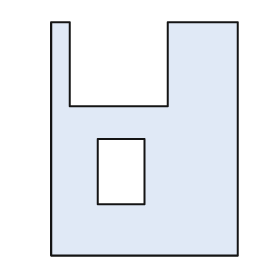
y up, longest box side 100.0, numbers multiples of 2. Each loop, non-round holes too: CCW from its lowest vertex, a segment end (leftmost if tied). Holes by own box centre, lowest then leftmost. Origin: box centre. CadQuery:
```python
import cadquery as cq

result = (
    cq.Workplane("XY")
    .moveTo(-40.0, -50.0)
    .lineTo(40.0, -50.0)
    .lineTo(40.0, 50.0)
    .lineTo(10.0, 50.0)
    .lineTo(10.0, 14.0)
    .lineTo(-32.0, 14.0)
    .lineTo(-32.0, 50.0)
    .lineTo(-40.0, 50.0)
    .close()
    .moveTo(-20.0, -28.0)
    .lineTo(0.0, -28.0)
    .lineTo(0.0, 0.0)
    .lineTo(-20.0, 0.0)
    .close()
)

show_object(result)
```